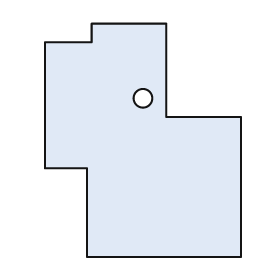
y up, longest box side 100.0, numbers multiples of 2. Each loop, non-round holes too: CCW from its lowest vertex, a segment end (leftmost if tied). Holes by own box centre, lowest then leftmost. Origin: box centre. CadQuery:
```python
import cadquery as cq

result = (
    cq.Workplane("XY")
    .moveTo(-24.0, -50.0)
    .lineTo(42.0, -50.0)
    .lineTo(42.0, 10.0)
    .lineTo(10.0, 10.0)
    .lineTo(10.0, 50.0)
    .lineTo(-22.0, 50.0)
    .lineTo(-22.0, 42.0)
    .lineTo(-42.0, 42.0)
    .lineTo(-42.0, -12.0)
    .lineTo(-24.0, -12.0)
    .close()
    .moveTo(0.0, 18.0)
    .circle(4.0)
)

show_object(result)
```